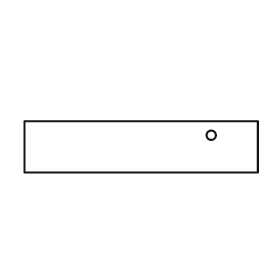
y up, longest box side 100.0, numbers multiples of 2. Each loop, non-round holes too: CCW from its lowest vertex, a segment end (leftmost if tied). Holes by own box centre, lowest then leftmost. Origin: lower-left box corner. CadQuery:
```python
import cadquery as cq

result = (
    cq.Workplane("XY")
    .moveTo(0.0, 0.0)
    .lineTo(100.0, 0.0)
    .lineTo(100.0, 22.0)
    .lineTo(0.0, 22.0)
    .close()
    .moveTo(80.0, 16.0)
    .circle(2.0)
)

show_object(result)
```